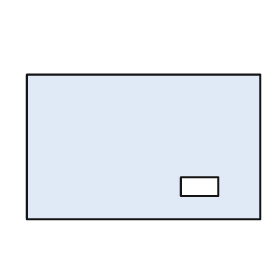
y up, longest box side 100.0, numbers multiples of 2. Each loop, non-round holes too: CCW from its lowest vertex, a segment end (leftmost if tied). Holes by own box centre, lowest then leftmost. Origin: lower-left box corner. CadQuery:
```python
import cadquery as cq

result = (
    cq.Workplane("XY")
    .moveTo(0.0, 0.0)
    .lineTo(100.0, 0.0)
    .lineTo(100.0, 62.0)
    .lineTo(0.0, 62.0)
    .close()
    .moveTo(66.0, 10.0)
    .lineTo(82.0, 10.0)
    .lineTo(82.0, 18.0)
    .lineTo(66.0, 18.0)
    .close()
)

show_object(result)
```